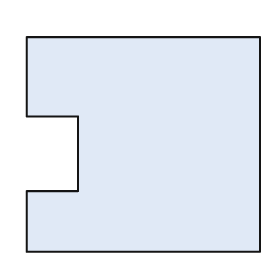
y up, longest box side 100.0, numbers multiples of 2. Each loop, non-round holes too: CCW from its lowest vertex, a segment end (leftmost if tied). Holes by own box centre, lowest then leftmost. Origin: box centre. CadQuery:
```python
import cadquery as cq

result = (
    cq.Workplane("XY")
    .moveTo(-50.0, -46.0)
    .lineTo(50.0, -46.0)
    .lineTo(50.0, 46.0)
    .lineTo(-50.0, 46.0)
    .lineTo(-50.0, 12.0)
    .lineTo(-28.0, 12.0)
    .lineTo(-28.0, -20.0)
    .lineTo(-50.0, -20.0)
    .close()
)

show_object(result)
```